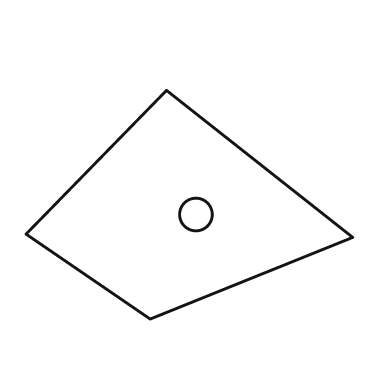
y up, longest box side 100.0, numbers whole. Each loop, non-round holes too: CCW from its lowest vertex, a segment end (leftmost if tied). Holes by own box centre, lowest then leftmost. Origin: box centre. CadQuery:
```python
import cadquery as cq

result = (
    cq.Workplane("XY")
    .moveTo(-12.0, -35.0)
    .lineTo(50.0, -10.0)
    .lineTo(-7.0, 35.0)
    .lineTo(-50.0, -9.0)
    .close()
    .moveTo(2.0, -3.0)
    .circle(5.0)
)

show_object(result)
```